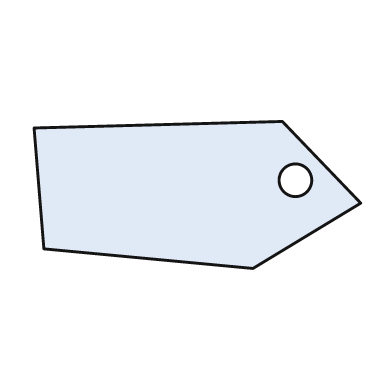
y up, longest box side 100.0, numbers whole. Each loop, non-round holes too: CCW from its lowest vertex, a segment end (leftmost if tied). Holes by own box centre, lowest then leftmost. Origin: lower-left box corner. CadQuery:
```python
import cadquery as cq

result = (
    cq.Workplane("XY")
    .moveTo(67.0, 0.0)
    .lineTo(100.0, 20.0)
    .lineTo(76.0, 45.0)
    .lineTo(0.0, 43.0)
    .lineTo(3.0, 6.0)
    .close()
    .moveTo(80.0, 27.0)
    .circle(5.0)
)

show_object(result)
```